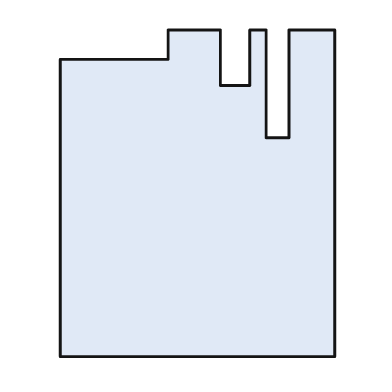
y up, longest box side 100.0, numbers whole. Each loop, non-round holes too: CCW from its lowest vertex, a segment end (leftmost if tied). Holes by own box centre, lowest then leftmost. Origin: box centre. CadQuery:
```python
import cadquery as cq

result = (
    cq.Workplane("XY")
    .moveTo(-42.0, -50.0)
    .lineTo(42.0, -50.0)
    .lineTo(42.0, 50.0)
    .lineTo(28.0, 50.0)
    .lineTo(28.0, 17.0)
    .lineTo(21.0, 17.0)
    .lineTo(21.0, 50.0)
    .lineTo(16.0, 50.0)
    .lineTo(16.0, 33.0)
    .lineTo(7.0, 33.0)
    .lineTo(7.0, 50.0)
    .lineTo(-9.0, 50.0)
    .lineTo(-9.0, 41.0)
    .lineTo(-42.0, 41.0)
    .close()
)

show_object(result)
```